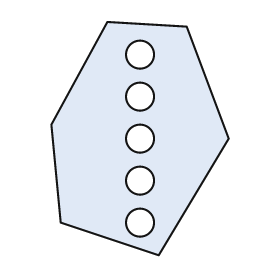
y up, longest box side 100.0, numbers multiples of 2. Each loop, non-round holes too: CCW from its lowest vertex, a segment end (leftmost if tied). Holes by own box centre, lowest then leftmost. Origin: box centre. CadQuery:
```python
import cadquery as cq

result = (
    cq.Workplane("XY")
    .moveTo(8.0, -50.0)
    .lineTo(38.0, 0.0)
    .lineTo(20.0, 48.0)
    .lineTo(-14.0, 50.0)
    .lineTo(-38.0, 6.0)
    .lineTo(-34.0, -36.0)
    .close()
    .moveTo(0.0, -36.0)
    .circle(6.0)
    .moveTo(0.0, -18.0)
    .circle(6.0)
    .moveTo(0.0, 0.0)
    .circle(6.0)
    .moveTo(0.0, 18.0)
    .circle(6.0)
    .moveTo(0.0, 36.0)
    .circle(6.0)
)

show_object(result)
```